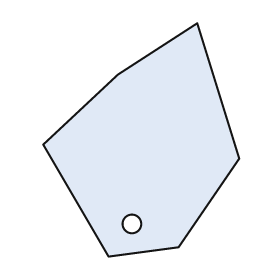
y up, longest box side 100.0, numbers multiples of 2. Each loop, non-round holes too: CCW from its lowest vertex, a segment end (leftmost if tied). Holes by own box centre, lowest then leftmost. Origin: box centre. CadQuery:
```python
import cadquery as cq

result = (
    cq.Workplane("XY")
    .moveTo(-14.0, -50.0)
    .lineTo(16.0, -46.0)
    .lineTo(42.0, -8.0)
    .lineTo(24.0, 50.0)
    .lineTo(-10.0, 28.0)
    .lineTo(-42.0, -2.0)
    .close()
    .moveTo(-4.0, -36.0)
    .circle(4.0)
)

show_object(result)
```